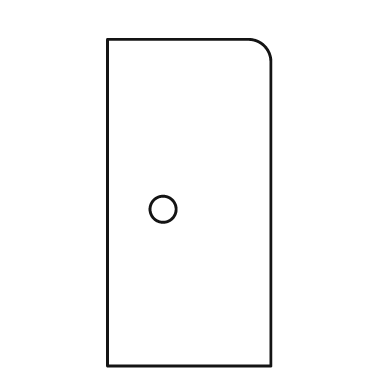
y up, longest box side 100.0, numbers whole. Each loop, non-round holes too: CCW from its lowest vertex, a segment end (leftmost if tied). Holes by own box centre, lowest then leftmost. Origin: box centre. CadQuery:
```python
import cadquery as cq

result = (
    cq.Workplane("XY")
    .moveTo(-25.0, -50.0)
    .lineTo(25.0, -50.0)
    .lineTo(25.0, 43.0)
    .threePointArc((23.0, 48.0), (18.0, 50.0))
    .lineTo(-25.0, 50.0)
    .close()
    .moveTo(-8.0, -2.0)
    .circle(4.0)
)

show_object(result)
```